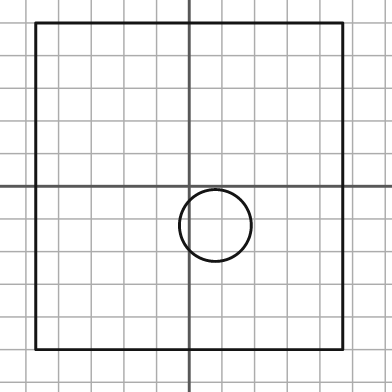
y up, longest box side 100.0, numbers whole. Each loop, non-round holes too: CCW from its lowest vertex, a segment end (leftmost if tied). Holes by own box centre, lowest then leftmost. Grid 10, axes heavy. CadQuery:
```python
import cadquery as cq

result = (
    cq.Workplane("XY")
    .moveTo(-47.0, -50.0)
    .lineTo(47.0, -50.0)
    .lineTo(47.0, 50.0)
    .lineTo(-47.0, 50.0)
    .close()
    .moveTo(8.0, -12.0)
    .circle(11.0)
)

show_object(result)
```